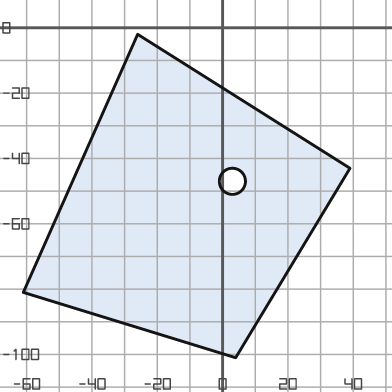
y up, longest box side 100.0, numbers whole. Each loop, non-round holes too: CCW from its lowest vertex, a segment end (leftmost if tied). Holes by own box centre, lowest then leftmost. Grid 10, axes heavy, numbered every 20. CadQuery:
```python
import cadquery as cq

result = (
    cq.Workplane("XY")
    .moveTo(4.0, -101.0)
    .lineTo(39.0, -43.0)
    .lineTo(-26.0, -2.0)
    .lineTo(-61.0, -81.0)
    .close()
    .moveTo(3.0, -47.0)
    .circle(4.0)
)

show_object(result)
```